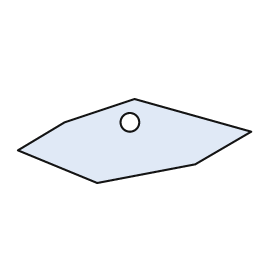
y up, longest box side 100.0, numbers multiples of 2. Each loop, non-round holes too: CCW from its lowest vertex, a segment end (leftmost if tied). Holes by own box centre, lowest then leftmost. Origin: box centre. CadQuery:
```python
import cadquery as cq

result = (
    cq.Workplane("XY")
    .moveTo(-16.0, -18.0)
    .lineTo(26.0, -10.0)
    .lineTo(50.0, 4.0)
    .lineTo(0.0, 18.0)
    .lineTo(-30.0, 8.0)
    .lineTo(-50.0, -4.0)
    .close()
    .moveTo(-2.0, 8.0)
    .circle(4.0)
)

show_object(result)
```